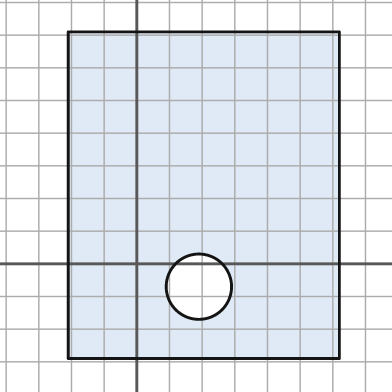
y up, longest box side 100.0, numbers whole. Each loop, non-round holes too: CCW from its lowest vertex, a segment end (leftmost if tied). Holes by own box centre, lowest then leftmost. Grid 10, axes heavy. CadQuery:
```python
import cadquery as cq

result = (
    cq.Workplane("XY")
    .moveTo(-21.0, -29.0)
    .lineTo(62.0, -29.0)
    .lineTo(62.0, 71.0)
    .lineTo(-21.0, 71.0)
    .close()
    .moveTo(19.0, -7.0)
    .circle(10.0)
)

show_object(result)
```